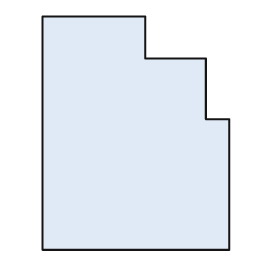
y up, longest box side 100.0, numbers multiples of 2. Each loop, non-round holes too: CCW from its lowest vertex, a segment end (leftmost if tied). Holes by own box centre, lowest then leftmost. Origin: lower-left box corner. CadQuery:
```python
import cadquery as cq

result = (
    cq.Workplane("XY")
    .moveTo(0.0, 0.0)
    .lineTo(80.0, 0.0)
    .lineTo(80.0, 56.0)
    .lineTo(70.0, 56.0)
    .lineTo(70.0, 82.0)
    .lineTo(44.0, 82.0)
    .lineTo(44.0, 100.0)
    .lineTo(0.0, 100.0)
    .close()
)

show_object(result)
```